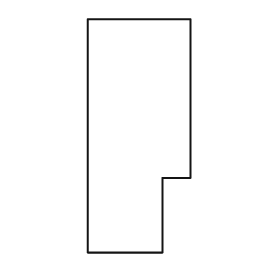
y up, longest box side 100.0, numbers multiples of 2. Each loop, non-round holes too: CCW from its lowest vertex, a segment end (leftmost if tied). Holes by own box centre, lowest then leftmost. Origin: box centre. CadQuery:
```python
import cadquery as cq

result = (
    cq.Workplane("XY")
    .moveTo(-22.0, -50.0)
    .lineTo(10.0, -50.0)
    .lineTo(10.0, -18.0)
    .lineTo(22.0, -18.0)
    .lineTo(22.0, 50.0)
    .lineTo(-22.0, 50.0)
    .close()
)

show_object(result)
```